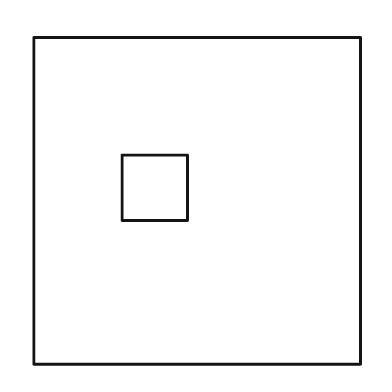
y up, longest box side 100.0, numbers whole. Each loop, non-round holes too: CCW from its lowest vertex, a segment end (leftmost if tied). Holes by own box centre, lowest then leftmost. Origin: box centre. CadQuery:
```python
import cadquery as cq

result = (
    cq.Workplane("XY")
    .moveTo(-50.0, -50.0)
    .lineTo(50.0, -50.0)
    .lineTo(50.0, 50.0)
    .lineTo(-50.0, 50.0)
    .close()
    .moveTo(-23.0, -6.0)
    .lineTo(-3.0, -6.0)
    .lineTo(-3.0, 14.0)
    .lineTo(-23.0, 14.0)
    .close()
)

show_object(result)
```